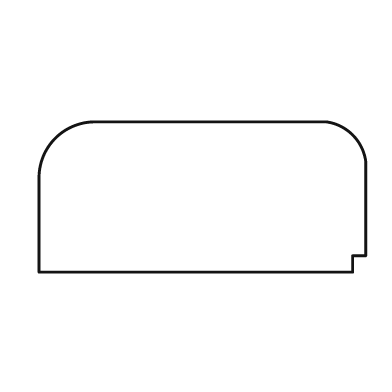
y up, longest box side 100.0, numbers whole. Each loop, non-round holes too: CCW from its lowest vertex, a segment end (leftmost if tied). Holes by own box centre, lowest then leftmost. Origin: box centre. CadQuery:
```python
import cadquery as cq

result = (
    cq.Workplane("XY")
    .moveTo(-50.0, -23.0)
    .lineTo(46.0, -23.0)
    .lineTo(46.0, -18.0)
    .lineTo(50.0, -18.0)
    .lineTo(50.0, 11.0)
    .threePointArc((46.0, 19.0), (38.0, 23.0))
    .lineTo(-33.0, 23.0)
    .threePointArc((-45.0, 18.0), (-50.0, 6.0))
    .close()
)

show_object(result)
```